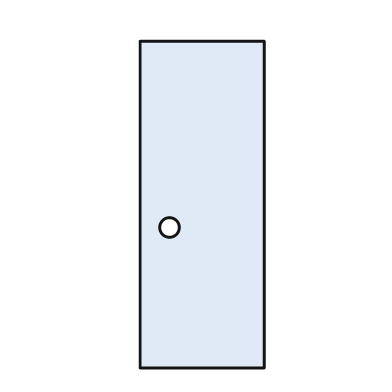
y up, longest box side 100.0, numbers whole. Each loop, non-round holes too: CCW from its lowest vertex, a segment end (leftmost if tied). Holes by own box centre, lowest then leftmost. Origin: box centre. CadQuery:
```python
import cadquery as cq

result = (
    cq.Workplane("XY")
    .moveTo(-19.0, -50.0)
    .lineTo(19.0, -50.0)
    .lineTo(19.0, 50.0)
    .lineTo(-19.0, 50.0)
    .close()
    .moveTo(-10.0, -7.0)
    .circle(3.0)
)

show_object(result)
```